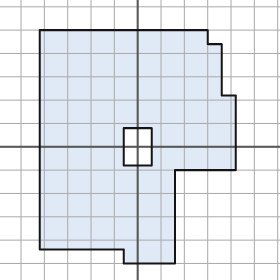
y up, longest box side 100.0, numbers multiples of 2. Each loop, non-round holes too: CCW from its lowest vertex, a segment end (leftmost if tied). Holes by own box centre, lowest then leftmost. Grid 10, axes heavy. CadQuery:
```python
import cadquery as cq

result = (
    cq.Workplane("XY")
    .moveTo(-6.0, -50.0)
    .lineTo(16.0, -50.0)
    .lineTo(16.0, -10.0)
    .lineTo(42.0, -10.0)
    .lineTo(42.0, 22.0)
    .lineTo(36.0, 22.0)
    .lineTo(36.0, 44.0)
    .lineTo(30.0, 44.0)
    .lineTo(30.0, 50.0)
    .lineTo(-42.0, 50.0)
    .lineTo(-42.0, -44.0)
    .lineTo(-6.0, -44.0)
    .close()
    .moveTo(-6.0, -8.0)
    .lineTo(6.0, -8.0)
    .lineTo(6.0, 8.0)
    .lineTo(-6.0, 8.0)
    .close()
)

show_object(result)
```